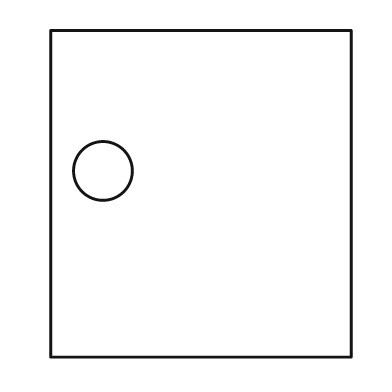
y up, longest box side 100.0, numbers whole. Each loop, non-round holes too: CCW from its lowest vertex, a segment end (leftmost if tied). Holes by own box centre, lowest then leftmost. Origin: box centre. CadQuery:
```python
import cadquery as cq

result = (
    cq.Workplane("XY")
    .moveTo(-46.0, -50.0)
    .lineTo(46.0, -50.0)
    .lineTo(46.0, 50.0)
    .lineTo(-46.0, 50.0)
    .close()
    .moveTo(-30.0, 7.0)
    .circle(9.0)
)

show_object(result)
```